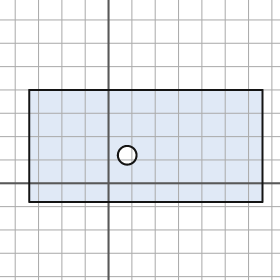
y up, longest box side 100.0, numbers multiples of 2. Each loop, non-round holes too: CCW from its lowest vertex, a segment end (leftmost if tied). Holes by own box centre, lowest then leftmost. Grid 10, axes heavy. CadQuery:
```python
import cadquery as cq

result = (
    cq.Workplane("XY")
    .moveTo(-34.0, -8.0)
    .lineTo(66.0, -8.0)
    .lineTo(66.0, 40.0)
    .lineTo(-34.0, 40.0)
    .close()
    .moveTo(8.0, 12.0)
    .circle(4.0)
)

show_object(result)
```